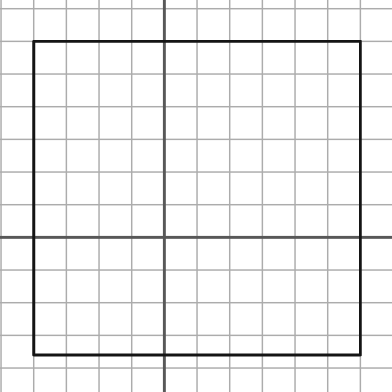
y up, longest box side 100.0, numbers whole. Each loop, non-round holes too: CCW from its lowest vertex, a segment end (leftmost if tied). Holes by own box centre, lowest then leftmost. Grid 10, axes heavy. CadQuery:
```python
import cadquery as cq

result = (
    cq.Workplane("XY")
    .moveTo(-40.0, -36.0)
    .lineTo(60.0, -36.0)
    .lineTo(60.0, 60.0)
    .lineTo(-40.0, 60.0)
    .close()
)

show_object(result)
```